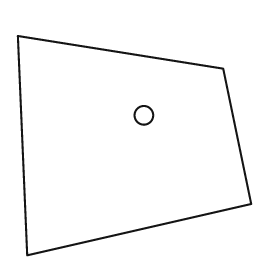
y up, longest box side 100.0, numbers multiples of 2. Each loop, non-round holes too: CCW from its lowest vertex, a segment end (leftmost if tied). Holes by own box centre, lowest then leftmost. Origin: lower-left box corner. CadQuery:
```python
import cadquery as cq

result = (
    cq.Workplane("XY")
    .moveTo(4.0, 0.0)
    .lineTo(100.0, 22.0)
    .lineTo(88.0, 80.0)
    .lineTo(0.0, 94.0)
    .close()
    .moveTo(54.0, 60.0)
    .circle(4.0)
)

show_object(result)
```